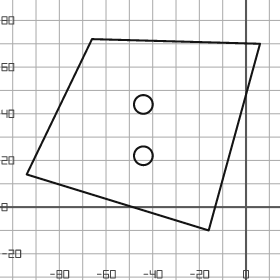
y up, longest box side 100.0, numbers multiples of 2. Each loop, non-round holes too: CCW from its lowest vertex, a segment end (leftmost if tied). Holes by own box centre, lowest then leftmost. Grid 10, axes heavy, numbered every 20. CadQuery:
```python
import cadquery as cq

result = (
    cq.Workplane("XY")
    .moveTo(-16.0, -10.0)
    .lineTo(6.0, 70.0)
    .lineTo(-66.0, 72.0)
    .lineTo(-94.0, 14.0)
    .close()
    .moveTo(-44.0, 22.0)
    .circle(4.0)
    .moveTo(-44.0, 44.0)
    .circle(4.0)
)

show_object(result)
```